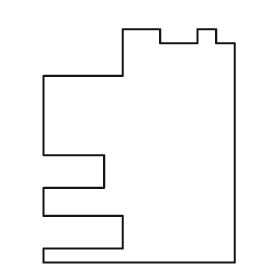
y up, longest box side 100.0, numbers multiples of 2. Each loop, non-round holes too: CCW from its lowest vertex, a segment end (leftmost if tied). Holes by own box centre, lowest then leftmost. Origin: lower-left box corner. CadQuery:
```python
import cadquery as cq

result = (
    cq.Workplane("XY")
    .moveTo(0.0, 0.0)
    .lineTo(82.0, 0.0)
    .lineTo(82.0, 94.0)
    .lineTo(74.0, 94.0)
    .lineTo(74.0, 100.0)
    .lineTo(66.0, 100.0)
    .lineTo(66.0, 94.0)
    .lineTo(50.0, 94.0)
    .lineTo(50.0, 100.0)
    .lineTo(34.0, 100.0)
    .lineTo(34.0, 80.0)
    .lineTo(0.0, 80.0)
    .lineTo(0.0, 46.0)
    .lineTo(26.0, 46.0)
    .lineTo(26.0, 32.0)
    .lineTo(0.0, 32.0)
    .lineTo(0.0, 20.0)
    .lineTo(34.0, 20.0)
    .lineTo(34.0, 6.0)
    .lineTo(0.0, 6.0)
    .close()
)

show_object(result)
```